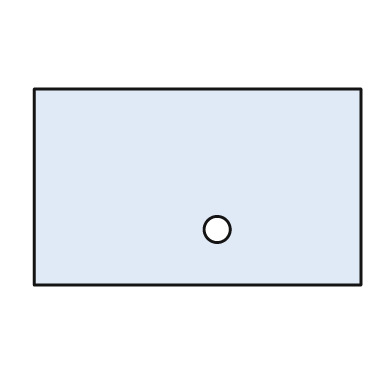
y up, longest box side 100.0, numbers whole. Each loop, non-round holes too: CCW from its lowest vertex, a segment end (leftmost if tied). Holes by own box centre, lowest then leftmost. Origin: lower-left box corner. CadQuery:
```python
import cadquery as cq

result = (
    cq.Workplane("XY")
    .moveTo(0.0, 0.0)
    .lineTo(100.0, 0.0)
    .lineTo(100.0, 60.0)
    .lineTo(0.0, 60.0)
    .close()
    .moveTo(56.0, 17.0)
    .circle(4.0)
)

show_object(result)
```